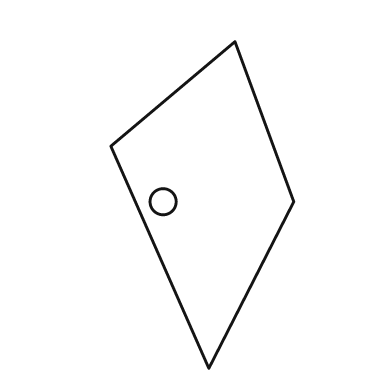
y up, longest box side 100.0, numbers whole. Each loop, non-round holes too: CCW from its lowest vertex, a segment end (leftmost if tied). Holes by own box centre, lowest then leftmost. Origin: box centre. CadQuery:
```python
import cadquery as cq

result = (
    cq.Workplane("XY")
    .moveTo(2.0, -50.0)
    .lineTo(28.0, 1.0)
    .lineTo(10.0, 50.0)
    .lineTo(-28.0, 18.0)
    .close()
    .moveTo(-12.0, 1.0)
    .circle(4.0)
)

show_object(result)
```